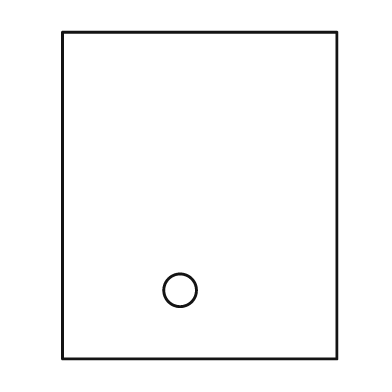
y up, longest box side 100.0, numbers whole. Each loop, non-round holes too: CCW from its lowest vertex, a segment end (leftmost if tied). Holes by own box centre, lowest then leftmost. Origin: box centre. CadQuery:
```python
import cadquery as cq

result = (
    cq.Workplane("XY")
    .moveTo(-42.0, -50.0)
    .lineTo(42.0, -50.0)
    .lineTo(42.0, 50.0)
    .lineTo(-42.0, 50.0)
    .close()
    .moveTo(-6.0, -29.0)
    .circle(5.0)
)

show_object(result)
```